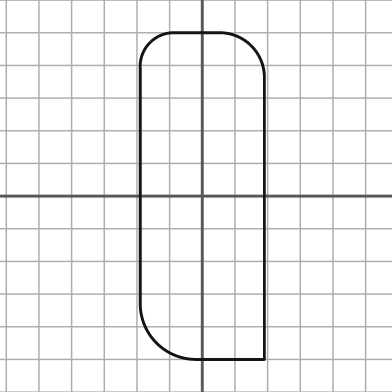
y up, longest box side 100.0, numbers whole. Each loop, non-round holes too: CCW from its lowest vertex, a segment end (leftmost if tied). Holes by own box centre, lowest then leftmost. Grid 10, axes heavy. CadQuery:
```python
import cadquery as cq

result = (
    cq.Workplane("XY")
    .moveTo(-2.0, -50.0)
    .lineTo(19.0, -50.0)
    .lineTo(19.0, 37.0)
    .threePointArc((15.0, 46.0), (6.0, 50.0))
    .lineTo(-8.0, 50.0)
    .threePointArc((-16.0, 47.0), (-19.0, 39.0))
    .lineTo(-19.0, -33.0)
    .threePointArc((-14.0, -45.0), (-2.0, -50.0))
    .close()
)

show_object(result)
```